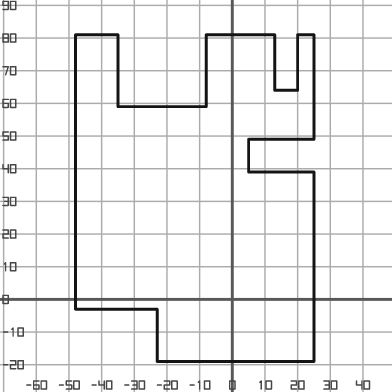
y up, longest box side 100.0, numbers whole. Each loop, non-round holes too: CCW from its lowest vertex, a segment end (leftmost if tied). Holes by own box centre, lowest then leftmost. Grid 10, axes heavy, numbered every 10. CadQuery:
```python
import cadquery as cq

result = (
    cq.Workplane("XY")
    .moveTo(-23.0, -19.0)
    .lineTo(25.0, -19.0)
    .lineTo(25.0, 39.0)
    .lineTo(5.0, 39.0)
    .lineTo(5.0, 49.0)
    .lineTo(25.0, 49.0)
    .lineTo(25.0, 81.0)
    .lineTo(20.0, 81.0)
    .lineTo(20.0, 64.0)
    .lineTo(13.0, 64.0)
    .lineTo(13.0, 81.0)
    .lineTo(-8.0, 81.0)
    .lineTo(-8.0, 59.0)
    .lineTo(-35.0, 59.0)
    .lineTo(-35.0, 81.0)
    .lineTo(-48.0, 81.0)
    .lineTo(-48.0, -3.0)
    .lineTo(-23.0, -3.0)
    .close()
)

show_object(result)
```